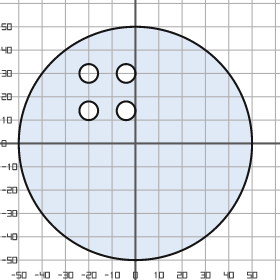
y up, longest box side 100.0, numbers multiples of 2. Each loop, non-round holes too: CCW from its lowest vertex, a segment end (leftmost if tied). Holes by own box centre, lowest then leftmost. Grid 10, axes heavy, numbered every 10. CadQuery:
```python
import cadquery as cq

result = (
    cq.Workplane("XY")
    .moveTo(0.0, 0.0)
    .circle(50.0)
    .moveTo(-20.0, 14.0)
    .circle(4.0)
    .moveTo(-4.0, 14.0)
    .circle(4.0)
    .moveTo(-20.0, 30.0)
    .circle(4.0)
    .moveTo(-4.0, 30.0)
    .circle(4.0)
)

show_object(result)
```